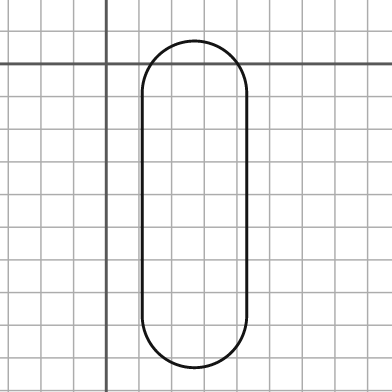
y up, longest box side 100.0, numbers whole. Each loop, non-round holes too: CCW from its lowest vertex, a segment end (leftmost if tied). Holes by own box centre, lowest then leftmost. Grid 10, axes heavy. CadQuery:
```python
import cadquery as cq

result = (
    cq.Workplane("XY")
    .moveTo(11.0, -77.0)
    .threePointArc((27.0, -93.0), (43.0, -77.0))
    .lineTo(43.0, -9.0)
    .threePointArc((27.0, 7.0), (11.0, -9.0))
    .close()
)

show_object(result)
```